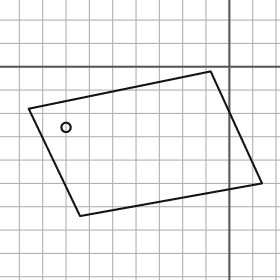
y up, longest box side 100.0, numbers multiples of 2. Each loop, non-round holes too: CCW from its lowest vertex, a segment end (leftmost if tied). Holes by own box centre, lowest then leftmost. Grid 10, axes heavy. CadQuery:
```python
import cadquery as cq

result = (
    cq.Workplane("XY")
    .moveTo(-64.0, -64.0)
    .lineTo(14.0, -50.0)
    .lineTo(-8.0, -2.0)
    .lineTo(-86.0, -18.0)
    .close()
    .moveTo(-70.0, -26.0)
    .circle(2.0)
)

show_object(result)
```